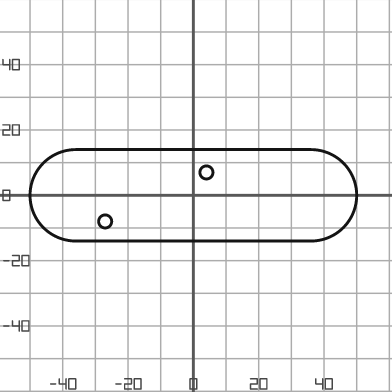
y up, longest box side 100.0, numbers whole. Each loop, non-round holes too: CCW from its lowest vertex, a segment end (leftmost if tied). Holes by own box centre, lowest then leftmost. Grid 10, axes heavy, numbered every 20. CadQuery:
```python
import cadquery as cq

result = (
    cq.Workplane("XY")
    .moveTo(-36.0, -14.0)
    .lineTo(36.0, -14.0)
    .threePointArc((50.0, 0.0), (36.0, 14.0))
    .lineTo(-36.0, 14.0)
    .threePointArc((-50.0, 0.0), (-36.0, -14.0))
    .close()
    .moveTo(-27.0, -8.0)
    .circle(2.0)
    .moveTo(4.0, 7.0)
    .circle(2.0)
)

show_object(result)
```